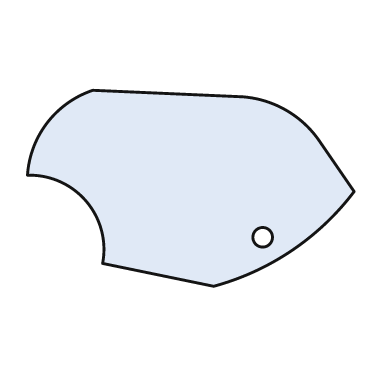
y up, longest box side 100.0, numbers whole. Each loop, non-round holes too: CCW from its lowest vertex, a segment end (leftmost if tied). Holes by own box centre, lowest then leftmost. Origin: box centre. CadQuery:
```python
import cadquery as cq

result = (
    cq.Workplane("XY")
    .moveTo(7.0, -30.0)
    .threePointArc((31.0, -19.0), (50.0, -1.0))
    .lineTo(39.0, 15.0)
    .threePointArc((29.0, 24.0), (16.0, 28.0))
    .lineTo(-30.0, 30.0)
    .threePointArc((-44.0, 20.0), (-50.0, 4.0))
    .threePointArc((-32.0, -4.0), (-27.0, -23.0))
    .close()
    .moveTo(22.0, -15.0)
    .circle(3.0)
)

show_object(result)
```